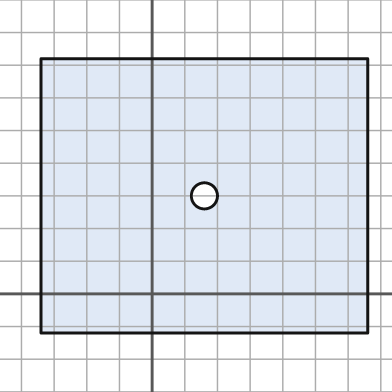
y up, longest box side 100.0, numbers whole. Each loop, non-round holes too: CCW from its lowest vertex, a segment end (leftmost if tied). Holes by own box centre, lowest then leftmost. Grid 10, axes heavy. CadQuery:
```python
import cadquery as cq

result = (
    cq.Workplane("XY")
    .moveTo(-34.0, -12.0)
    .lineTo(66.0, -12.0)
    .lineTo(66.0, 72.0)
    .lineTo(-34.0, 72.0)
    .close()
    .moveTo(16.0, 30.0)
    .circle(4.0)
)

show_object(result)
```